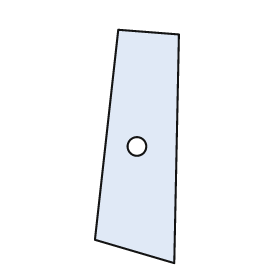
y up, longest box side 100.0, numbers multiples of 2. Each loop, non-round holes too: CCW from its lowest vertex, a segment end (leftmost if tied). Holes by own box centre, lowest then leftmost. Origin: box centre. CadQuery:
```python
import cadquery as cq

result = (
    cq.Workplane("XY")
    .moveTo(16.0, -50.0)
    .lineTo(18.0, 48.0)
    .lineTo(-8.0, 50.0)
    .lineTo(-18.0, -40.0)
    .close()
    .moveTo(0.0, 0.0)
    .circle(4.0)
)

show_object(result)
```